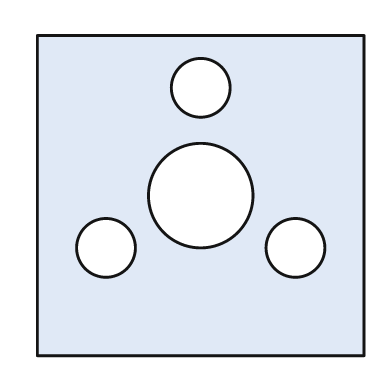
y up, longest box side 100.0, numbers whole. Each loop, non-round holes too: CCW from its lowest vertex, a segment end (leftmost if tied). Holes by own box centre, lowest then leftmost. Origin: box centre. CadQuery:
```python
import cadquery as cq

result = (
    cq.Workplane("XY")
    .moveTo(-50.0, -49.0)
    .lineTo(50.0, -49.0)
    .lineTo(50.0, 49.0)
    .lineTo(-50.0, 49.0)
    .close()
    .moveTo(-29.0, -16.0)
    .circle(9.0)
    .moveTo(29.0, -16.0)
    .circle(9.0)
    .moveTo(0.0, 0.0)
    .circle(16.0)
    .moveTo(0.0, 33.0)
    .circle(9.0)
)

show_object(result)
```